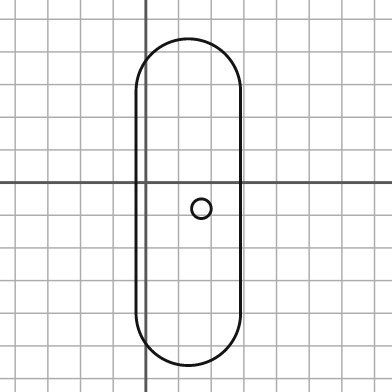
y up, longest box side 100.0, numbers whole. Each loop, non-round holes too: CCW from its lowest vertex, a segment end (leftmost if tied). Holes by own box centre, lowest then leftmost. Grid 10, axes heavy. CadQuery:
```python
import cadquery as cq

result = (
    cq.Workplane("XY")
    .moveTo(-3.0, -40.0)
    .threePointArc((13.0, -56.0), (29.0, -40.0))
    .lineTo(29.0, 28.0)
    .threePointArc((13.0, 44.0), (-3.0, 28.0))
    .close()
    .moveTo(17.0, -8.0)
    .circle(3.0)
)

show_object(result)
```